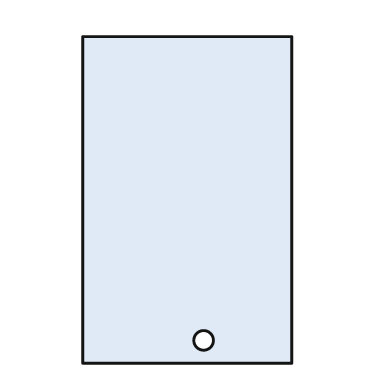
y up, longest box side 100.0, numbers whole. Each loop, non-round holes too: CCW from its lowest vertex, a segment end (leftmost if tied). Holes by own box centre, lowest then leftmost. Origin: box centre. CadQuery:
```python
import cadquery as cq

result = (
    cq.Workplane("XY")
    .moveTo(-32.0, -50.0)
    .lineTo(32.0, -50.0)
    .lineTo(32.0, 50.0)
    .lineTo(-32.0, 50.0)
    .close()
    .moveTo(5.0, -43.0)
    .circle(3.0)
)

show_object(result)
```